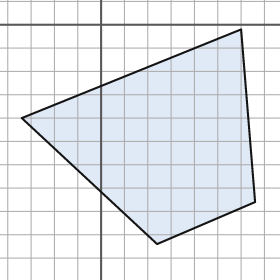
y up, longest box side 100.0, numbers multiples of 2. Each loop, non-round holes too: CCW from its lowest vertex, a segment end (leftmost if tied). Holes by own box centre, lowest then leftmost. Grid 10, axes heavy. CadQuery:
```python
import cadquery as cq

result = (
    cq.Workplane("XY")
    .moveTo(24.0, -94.0)
    .lineTo(66.0, -76.0)
    .lineTo(60.0, -2.0)
    .lineTo(-34.0, -40.0)
    .close()
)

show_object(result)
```